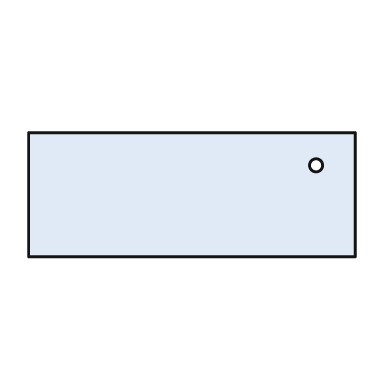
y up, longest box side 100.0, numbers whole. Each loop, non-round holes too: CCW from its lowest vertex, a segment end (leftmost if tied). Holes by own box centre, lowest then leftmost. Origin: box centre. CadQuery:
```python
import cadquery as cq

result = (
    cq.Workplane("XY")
    .moveTo(-50.0, -19.0)
    .lineTo(50.0, -19.0)
    .lineTo(50.0, 19.0)
    .lineTo(-50.0, 19.0)
    .close()
    .moveTo(38.0, 9.0)
    .circle(2.0)
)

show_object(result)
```